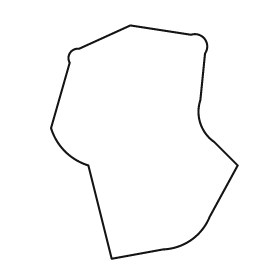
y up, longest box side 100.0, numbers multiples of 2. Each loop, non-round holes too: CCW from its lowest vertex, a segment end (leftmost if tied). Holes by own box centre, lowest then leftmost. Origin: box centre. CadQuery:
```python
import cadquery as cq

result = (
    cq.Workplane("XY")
    .moveTo(-14.0, -50.0)
    .lineTo(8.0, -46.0)
    .threePointArc((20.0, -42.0), (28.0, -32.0))
    .lineTo(40.0, -10.0)
    .lineTo(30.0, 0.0)
    .threePointArc((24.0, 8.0), (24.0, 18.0))
    .lineTo(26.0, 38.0)
    .threePointArc((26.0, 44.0), (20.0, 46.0))
    .lineTo(-6.0, 50.0)
    .lineTo(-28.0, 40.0)
    .threePointArc((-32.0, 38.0), (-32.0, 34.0))
    .lineTo(-40.0, 6.0)
    .threePointArc((-34.0, -4.0), (-24.0, -10.0))
    .close()
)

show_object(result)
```